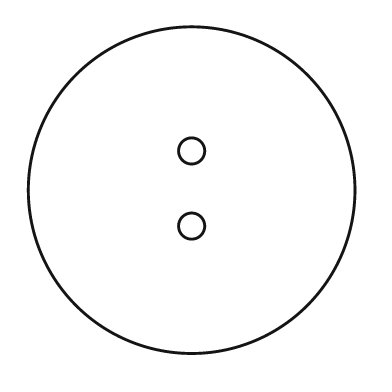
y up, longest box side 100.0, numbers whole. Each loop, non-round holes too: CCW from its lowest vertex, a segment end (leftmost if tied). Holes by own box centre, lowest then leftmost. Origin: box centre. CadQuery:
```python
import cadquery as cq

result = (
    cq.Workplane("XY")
    .moveTo(0.0, 0.0)
    .circle(50.0)
    .moveTo(0.0, -11.0)
    .circle(4.0)
    .moveTo(0.0, 12.0)
    .circle(4.0)
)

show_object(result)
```